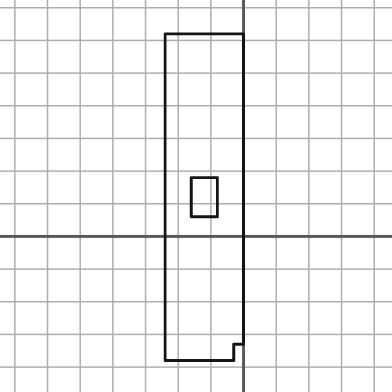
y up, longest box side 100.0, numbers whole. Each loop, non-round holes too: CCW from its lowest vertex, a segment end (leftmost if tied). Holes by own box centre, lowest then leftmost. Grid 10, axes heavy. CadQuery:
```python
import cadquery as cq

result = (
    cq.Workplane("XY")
    .moveTo(-24.0, -38.0)
    .lineTo(-3.0, -38.0)
    .lineTo(-3.0, -33.0)
    .lineTo(0.0, -33.0)
    .lineTo(0.0, 62.0)
    .lineTo(-24.0, 62.0)
    .close()
    .moveTo(-16.0, 6.0)
    .lineTo(-8.0, 6.0)
    .lineTo(-8.0, 18.0)
    .lineTo(-16.0, 18.0)
    .close()
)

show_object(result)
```